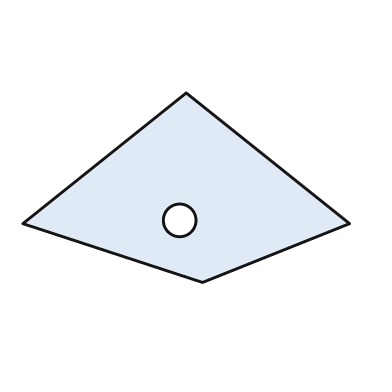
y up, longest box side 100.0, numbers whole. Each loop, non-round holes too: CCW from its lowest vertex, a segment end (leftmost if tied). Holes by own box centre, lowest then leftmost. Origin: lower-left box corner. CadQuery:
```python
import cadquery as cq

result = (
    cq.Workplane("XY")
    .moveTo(55.0, 0.0)
    .lineTo(100.0, 18.0)
    .lineTo(50.0, 58.0)
    .lineTo(0.0, 18.0)
    .close()
    .moveTo(48.0, 19.0)
    .circle(5.0)
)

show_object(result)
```